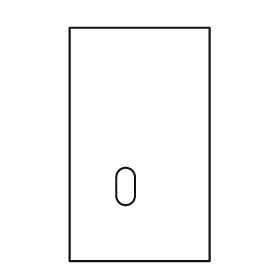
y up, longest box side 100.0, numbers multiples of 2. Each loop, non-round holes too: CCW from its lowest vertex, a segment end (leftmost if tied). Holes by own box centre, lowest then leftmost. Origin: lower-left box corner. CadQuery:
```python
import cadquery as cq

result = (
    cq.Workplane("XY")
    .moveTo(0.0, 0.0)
    .lineTo(60.0, 0.0)
    .lineTo(60.0, 100.0)
    .lineTo(0.0, 100.0)
    .close()
    .moveTo(20.0, 28.0)
    .threePointArc((24.0, 24.0), (28.0, 28.0))
    .lineTo(28.0, 36.0)
    .threePointArc((24.0, 40.0), (20.0, 36.0))
    .close()
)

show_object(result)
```